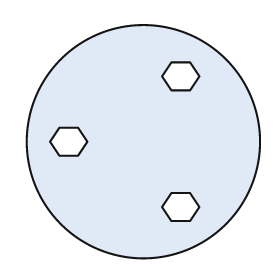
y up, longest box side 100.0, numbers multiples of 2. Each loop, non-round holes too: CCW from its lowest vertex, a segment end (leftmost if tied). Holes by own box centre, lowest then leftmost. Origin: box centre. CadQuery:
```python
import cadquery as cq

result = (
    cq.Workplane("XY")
    .moveTo(0.0, 0.0)
    .circle(50.0)
    .moveTo(12.0, -34.0)
    .lineTo(20.0, -34.0)
    .lineTo(24.0, -28.0)
    .lineTo(20.0, -22.0)
    .lineTo(12.0, -22.0)
    .lineTo(8.0, -28.0)
    .close()
    .moveTo(-36.0, -6.0)
    .lineTo(-28.0, -6.0)
    .lineTo(-24.0, 0.0)
    .lineTo(-28.0, 6.0)
    .lineTo(-36.0, 6.0)
    .lineTo(-40.0, 0.0)
    .close()
    .moveTo(12.0, 22.0)
    .lineTo(20.0, 22.0)
    .lineTo(24.0, 28.0)
    .lineTo(20.0, 34.0)
    .lineTo(12.0, 34.0)
    .lineTo(8.0, 28.0)
    .close()
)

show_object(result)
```